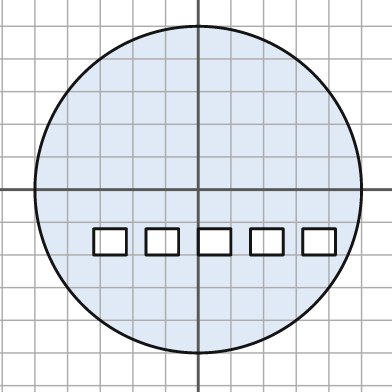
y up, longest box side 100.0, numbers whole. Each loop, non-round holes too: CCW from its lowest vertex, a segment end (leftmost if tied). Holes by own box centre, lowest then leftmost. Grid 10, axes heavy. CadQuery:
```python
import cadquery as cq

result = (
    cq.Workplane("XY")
    .moveTo(0.0, 0.0)
    .circle(50.0)
    .moveTo(-32.0, -20.0)
    .lineTo(-22.0, -20.0)
    .lineTo(-22.0, -12.0)
    .lineTo(-32.0, -12.0)
    .close()
    .moveTo(-16.0, -20.0)
    .lineTo(-6.0, -20.0)
    .lineTo(-6.0, -12.0)
    .lineTo(-16.0, -12.0)
    .close()
    .moveTo(0.0, -20.0)
    .lineTo(10.0, -20.0)
    .lineTo(10.0, -12.0)
    .lineTo(0.0, -12.0)
    .close()
    .moveTo(16.0, -20.0)
    .lineTo(26.0, -20.0)
    .lineTo(26.0, -12.0)
    .lineTo(16.0, -12.0)
    .close()
    .moveTo(32.0, -20.0)
    .lineTo(42.0, -20.0)
    .lineTo(42.0, -12.0)
    .lineTo(32.0, -12.0)
    .close()
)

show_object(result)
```